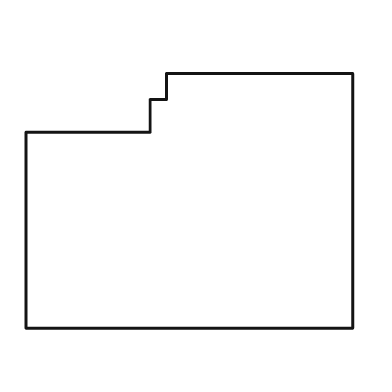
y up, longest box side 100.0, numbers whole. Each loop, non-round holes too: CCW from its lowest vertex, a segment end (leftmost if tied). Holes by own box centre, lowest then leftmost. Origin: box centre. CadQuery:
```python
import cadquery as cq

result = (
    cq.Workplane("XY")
    .moveTo(-50.0, -39.0)
    .lineTo(50.0, -39.0)
    .lineTo(50.0, 39.0)
    .lineTo(-7.0, 39.0)
    .lineTo(-7.0, 31.0)
    .lineTo(-12.0, 31.0)
    .lineTo(-12.0, 21.0)
    .lineTo(-50.0, 21.0)
    .close()
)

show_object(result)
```